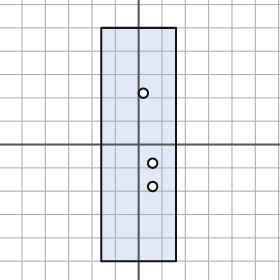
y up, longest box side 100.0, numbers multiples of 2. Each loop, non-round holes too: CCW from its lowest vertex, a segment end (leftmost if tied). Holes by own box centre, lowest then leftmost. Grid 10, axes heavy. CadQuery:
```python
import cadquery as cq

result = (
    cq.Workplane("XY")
    .moveTo(-16.0, -50.0)
    .lineTo(16.0, -50.0)
    .lineTo(16.0, 50.0)
    .lineTo(-16.0, 50.0)
    .close()
    .moveTo(6.0, -18.0)
    .circle(2.0)
    .moveTo(6.0, -8.0)
    .circle(2.0)
    .moveTo(2.0, 22.0)
    .circle(2.0)
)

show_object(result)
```